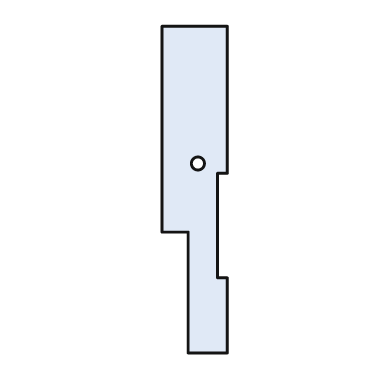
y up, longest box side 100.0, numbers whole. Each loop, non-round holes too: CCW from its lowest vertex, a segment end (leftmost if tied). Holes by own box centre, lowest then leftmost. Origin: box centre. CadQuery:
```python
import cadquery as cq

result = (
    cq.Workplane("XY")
    .moveTo(-2.0, -50.0)
    .lineTo(10.0, -50.0)
    .lineTo(10.0, -27.0)
    .lineTo(7.0, -27.0)
    .lineTo(7.0, 5.0)
    .lineTo(10.0, 5.0)
    .lineTo(10.0, 50.0)
    .lineTo(-10.0, 50.0)
    .lineTo(-10.0, -13.0)
    .lineTo(-2.0, -13.0)
    .close()
    .moveTo(1.0, 8.0)
    .circle(2.0)
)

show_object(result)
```